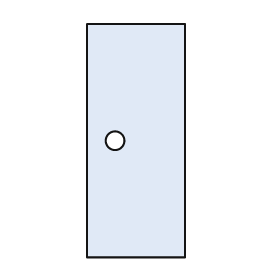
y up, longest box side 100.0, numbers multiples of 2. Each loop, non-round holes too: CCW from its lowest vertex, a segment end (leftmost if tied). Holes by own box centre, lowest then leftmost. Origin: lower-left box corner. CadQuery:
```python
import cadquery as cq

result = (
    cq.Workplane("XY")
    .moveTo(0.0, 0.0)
    .lineTo(42.0, 0.0)
    .lineTo(42.0, 100.0)
    .lineTo(0.0, 100.0)
    .close()
    .moveTo(12.0, 50.0)
    .circle(4.0)
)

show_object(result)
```